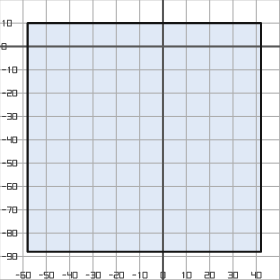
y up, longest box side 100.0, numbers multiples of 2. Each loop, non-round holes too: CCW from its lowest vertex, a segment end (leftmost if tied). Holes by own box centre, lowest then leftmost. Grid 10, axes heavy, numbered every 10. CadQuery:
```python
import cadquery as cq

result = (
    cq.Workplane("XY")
    .moveTo(-58.0, -88.0)
    .lineTo(42.0, -88.0)
    .lineTo(42.0, 10.0)
    .lineTo(-58.0, 10.0)
    .close()
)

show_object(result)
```